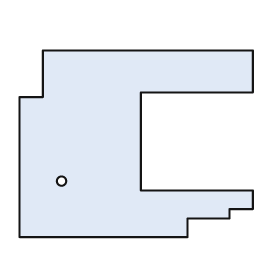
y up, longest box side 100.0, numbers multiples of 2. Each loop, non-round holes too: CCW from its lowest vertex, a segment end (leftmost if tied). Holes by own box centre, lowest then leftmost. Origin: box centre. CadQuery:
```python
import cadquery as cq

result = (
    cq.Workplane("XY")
    .moveTo(-50.0, -40.0)
    .lineTo(22.0, -40.0)
    .lineTo(22.0, -32.0)
    .lineTo(40.0, -32.0)
    .lineTo(40.0, -28.0)
    .lineTo(50.0, -28.0)
    .lineTo(50.0, -20.0)
    .lineTo(2.0, -20.0)
    .lineTo(2.0, 22.0)
    .lineTo(50.0, 22.0)
    .lineTo(50.0, 40.0)
    .lineTo(-40.0, 40.0)
    .lineTo(-40.0, 20.0)
    .lineTo(-50.0, 20.0)
    .close()
    .moveTo(-32.0, -16.0)
    .circle(2.0)
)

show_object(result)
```